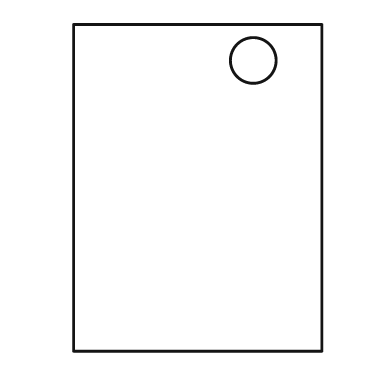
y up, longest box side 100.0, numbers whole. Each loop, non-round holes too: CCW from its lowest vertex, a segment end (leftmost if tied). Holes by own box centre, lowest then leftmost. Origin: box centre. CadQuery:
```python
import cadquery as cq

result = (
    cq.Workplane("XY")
    .moveTo(-38.0, -50.0)
    .lineTo(38.0, -50.0)
    .lineTo(38.0, 50.0)
    .lineTo(-38.0, 50.0)
    .close()
    .moveTo(17.0, 39.0)
    .circle(7.0)
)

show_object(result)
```